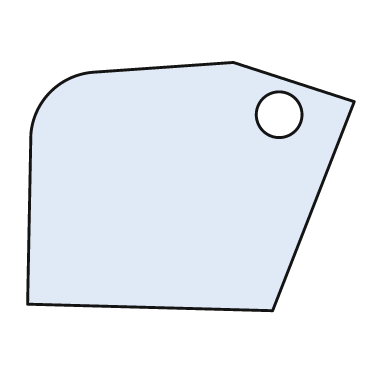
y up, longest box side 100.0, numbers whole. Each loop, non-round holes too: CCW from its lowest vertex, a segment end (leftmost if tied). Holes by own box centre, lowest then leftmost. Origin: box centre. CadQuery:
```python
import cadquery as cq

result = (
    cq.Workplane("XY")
    .moveTo(25.0, -38.0)
    .lineTo(50.0, 26.0)
    .lineTo(13.0, 38.0)
    .lineTo(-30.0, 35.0)
    .threePointArc((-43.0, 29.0), (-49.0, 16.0))
    .lineTo(-50.0, -36.0)
    .close()
    .moveTo(27.0, 22.0)
    .circle(7.0)
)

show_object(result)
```